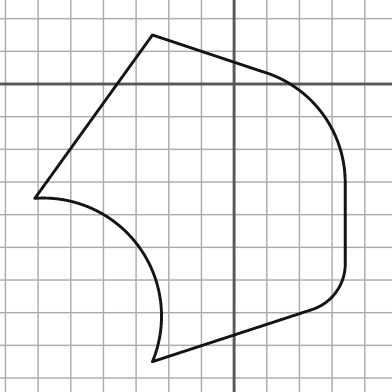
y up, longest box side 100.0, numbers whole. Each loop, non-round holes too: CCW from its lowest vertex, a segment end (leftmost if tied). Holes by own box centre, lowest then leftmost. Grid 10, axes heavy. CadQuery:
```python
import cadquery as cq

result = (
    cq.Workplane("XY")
    .moveTo(-25.0, -85.0)
    .lineTo(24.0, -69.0)
    .threePointArc((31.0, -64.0), (34.0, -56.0))
    .lineTo(34.0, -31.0)
    .threePointArc((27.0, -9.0), (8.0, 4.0))
    .lineTo(-25.0, 15.0)
    .lineTo(-61.0, -35.0)
    .threePointArc((-29.0, -50.0), (-25.0, -85.0))
    .close()
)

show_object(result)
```